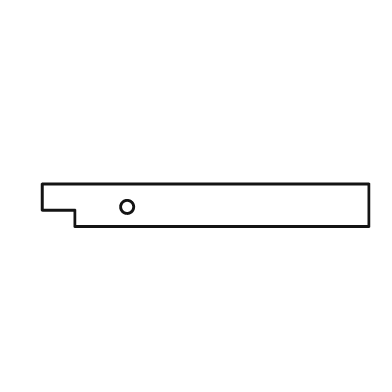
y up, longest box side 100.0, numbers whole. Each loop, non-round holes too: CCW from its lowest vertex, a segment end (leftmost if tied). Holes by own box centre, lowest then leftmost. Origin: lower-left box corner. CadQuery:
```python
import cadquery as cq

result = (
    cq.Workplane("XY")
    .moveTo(10.0, 0.0)
    .lineTo(100.0, 0.0)
    .lineTo(100.0, 13.0)
    .lineTo(0.0, 13.0)
    .lineTo(0.0, 5.0)
    .lineTo(10.0, 5.0)
    .close()
    .moveTo(26.0, 6.0)
    .circle(2.0)
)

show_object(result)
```